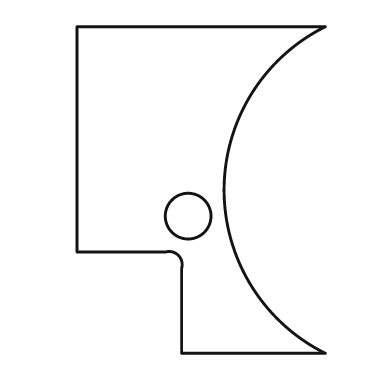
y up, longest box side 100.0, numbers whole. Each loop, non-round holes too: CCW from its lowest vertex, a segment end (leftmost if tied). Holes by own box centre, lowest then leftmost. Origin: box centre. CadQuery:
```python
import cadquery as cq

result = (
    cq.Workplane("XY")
    .moveTo(-6.0, -50.0)
    .lineTo(38.0, -50.0)
    .threePointArc((7.0, 0.0), (38.0, 50.0))
    .lineTo(-38.0, 50.0)
    .lineTo(-38.0, -19.0)
    .lineTo(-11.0, -19.0)
    .threePointArc((-7.0, -20.0), (-6.0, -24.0))
    .close()
    .moveTo(-4.0, -8.0)
    .circle(7.0)
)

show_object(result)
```